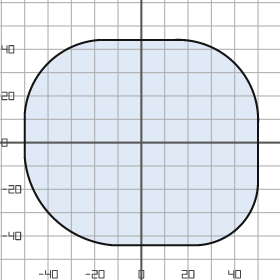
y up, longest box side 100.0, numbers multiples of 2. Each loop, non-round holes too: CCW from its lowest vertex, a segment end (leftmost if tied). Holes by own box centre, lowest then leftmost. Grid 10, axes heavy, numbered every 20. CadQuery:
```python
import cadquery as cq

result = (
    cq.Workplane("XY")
    .moveTo(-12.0, -44.0)
    .lineTo(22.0, -44.0)
    .threePointArc((42.0, -36.0), (50.0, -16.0))
    .lineTo(50.0, 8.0)
    .threePointArc((40.0, 34.0), (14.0, 44.0))
    .lineTo(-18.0, 44.0)
    .threePointArc((-40.0, 34.0), (-50.0, 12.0))
    .lineTo(-50.0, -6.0)
    .threePointArc((-38.0, -32.0), (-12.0, -44.0))
    .close()
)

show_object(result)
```